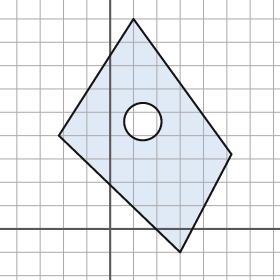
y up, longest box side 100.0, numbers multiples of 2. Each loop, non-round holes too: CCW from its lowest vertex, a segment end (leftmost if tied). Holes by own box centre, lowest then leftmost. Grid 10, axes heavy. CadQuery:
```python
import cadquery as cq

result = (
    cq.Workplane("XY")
    .moveTo(30.0, -10.0)
    .lineTo(52.0, 32.0)
    .lineTo(10.0, 90.0)
    .lineTo(-22.0, 40.0)
    .close()
    .moveTo(14.0, 46.0)
    .circle(8.0)
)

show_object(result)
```